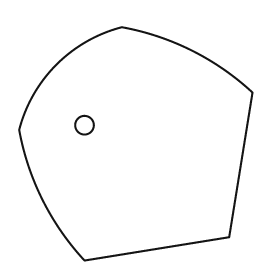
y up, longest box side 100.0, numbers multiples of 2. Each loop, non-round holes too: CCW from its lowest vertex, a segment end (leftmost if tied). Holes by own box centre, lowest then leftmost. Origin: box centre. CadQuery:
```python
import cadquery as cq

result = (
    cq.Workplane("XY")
    .moveTo(-22.0, -50.0)
    .lineTo(40.0, -40.0)
    .lineTo(50.0, 22.0)
    .threePointArc((24.0, 40.0), (-6.0, 50.0))
    .threePointArc((-34.0, 34.0), (-50.0, 6.0))
    .threePointArc((-40.0, -24.0), (-22.0, -50.0))
    .close()
    .moveTo(-22.0, 8.0)
    .circle(4.0)
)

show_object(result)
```